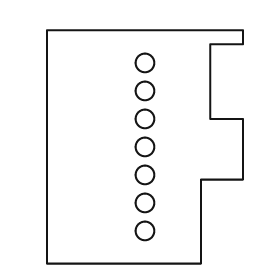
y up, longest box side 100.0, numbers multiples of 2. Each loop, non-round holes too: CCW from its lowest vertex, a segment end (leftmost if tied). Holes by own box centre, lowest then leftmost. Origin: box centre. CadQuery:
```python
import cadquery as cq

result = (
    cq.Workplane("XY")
    .moveTo(-42.0, -50.0)
    .lineTo(24.0, -50.0)
    .lineTo(24.0, -14.0)
    .lineTo(42.0, -14.0)
    .lineTo(42.0, 12.0)
    .lineTo(28.0, 12.0)
    .lineTo(28.0, 44.0)
    .lineTo(42.0, 44.0)
    .lineTo(42.0, 50.0)
    .lineTo(-42.0, 50.0)
    .close()
    .moveTo(0.0, -36.0)
    .circle(4.0)
    .moveTo(0.0, -24.0)
    .circle(4.0)
    .moveTo(0.0, -12.0)
    .circle(4.0)
    .moveTo(0.0, 0.0)
    .circle(4.0)
    .moveTo(0.0, 12.0)
    .circle(4.0)
    .moveTo(0.0, 24.0)
    .circle(4.0)
    .moveTo(0.0, 36.0)
    .circle(4.0)
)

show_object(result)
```